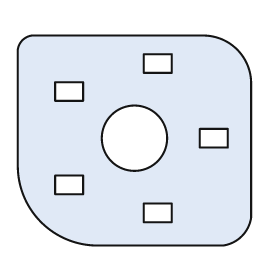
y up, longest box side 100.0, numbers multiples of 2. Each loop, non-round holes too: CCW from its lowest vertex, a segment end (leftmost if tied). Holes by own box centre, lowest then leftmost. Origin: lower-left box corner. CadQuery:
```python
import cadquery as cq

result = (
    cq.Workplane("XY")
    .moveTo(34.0, 0.0)
    .lineTo(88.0, 0.0)
    .threePointArc((96.0, 4.0), (100.0, 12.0))
    .lineTo(100.0, 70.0)
    .threePointArc((94.0, 84.0), (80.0, 90.0))
    .lineTo(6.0, 90.0)
    .threePointArc((2.0, 88.0), (0.0, 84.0))
    .lineTo(0.0, 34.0)
    .threePointArc((10.0, 10.0), (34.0, 0.0))
    .close()
    .moveTo(54.0, 10.0)
    .lineTo(66.0, 10.0)
    .lineTo(66.0, 18.0)
    .lineTo(54.0, 18.0)
    .close()
    .moveTo(16.0, 22.0)
    .lineTo(28.0, 22.0)
    .lineTo(28.0, 30.0)
    .lineTo(16.0, 30.0)
    .close()
    .moveTo(50.0, 46.0)
    .circle(14.0)
    .moveTo(78.0, 42.0)
    .lineTo(90.0, 42.0)
    .lineTo(90.0, 50.0)
    .lineTo(78.0, 50.0)
    .close()
    .moveTo(16.0, 62.0)
    .lineTo(28.0, 62.0)
    .lineTo(28.0, 70.0)
    .lineTo(16.0, 70.0)
    .close()
    .moveTo(54.0, 74.0)
    .lineTo(66.0, 74.0)
    .lineTo(66.0, 82.0)
    .lineTo(54.0, 82.0)
    .close()
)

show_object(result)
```